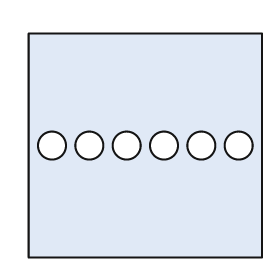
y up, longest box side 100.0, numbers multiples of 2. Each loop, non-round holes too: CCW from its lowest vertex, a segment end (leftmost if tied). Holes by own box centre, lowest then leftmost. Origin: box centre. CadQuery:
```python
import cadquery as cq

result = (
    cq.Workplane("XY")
    .moveTo(-50.0, -48.0)
    .lineTo(50.0, -48.0)
    .lineTo(50.0, 48.0)
    .lineTo(-50.0, 48.0)
    .close()
    .moveTo(-40.0, 0.0)
    .circle(6.0)
    .moveTo(-24.0, 0.0)
    .circle(6.0)
    .moveTo(-8.0, 0.0)
    .circle(6.0)
    .moveTo(8.0, 0.0)
    .circle(6.0)
    .moveTo(24.0, 0.0)
    .circle(6.0)
    .moveTo(40.0, 0.0)
    .circle(6.0)
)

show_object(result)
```